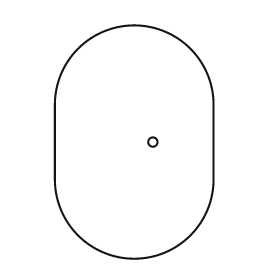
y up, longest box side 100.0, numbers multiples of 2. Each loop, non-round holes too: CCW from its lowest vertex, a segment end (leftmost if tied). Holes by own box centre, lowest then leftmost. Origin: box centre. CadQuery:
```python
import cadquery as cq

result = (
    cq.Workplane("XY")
    .moveTo(-34.0, -16.0)
    .threePointArc((0.0, -50.0), (34.0, -16.0))
    .lineTo(34.0, 16.0)
    .threePointArc((0.0, 50.0), (-34.0, 16.0))
    .close()
    .moveTo(8.0, 0.0)
    .circle(2.0)
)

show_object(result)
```